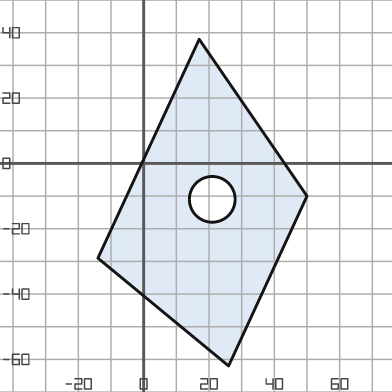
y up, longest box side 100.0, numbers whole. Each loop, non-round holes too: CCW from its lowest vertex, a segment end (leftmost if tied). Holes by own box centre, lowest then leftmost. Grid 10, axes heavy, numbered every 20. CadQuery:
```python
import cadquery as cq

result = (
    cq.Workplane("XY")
    .moveTo(26.0, -62.0)
    .lineTo(50.0, -10.0)
    .lineTo(17.0, 38.0)
    .lineTo(-14.0, -29.0)
    .close()
    .moveTo(21.0, -11.0)
    .circle(7.0)
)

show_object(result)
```